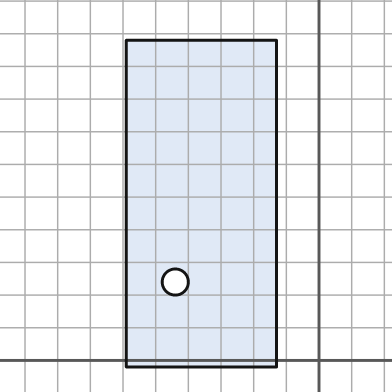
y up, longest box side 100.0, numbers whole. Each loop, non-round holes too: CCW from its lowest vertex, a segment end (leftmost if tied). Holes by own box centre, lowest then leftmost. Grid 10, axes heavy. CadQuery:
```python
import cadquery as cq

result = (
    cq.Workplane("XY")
    .moveTo(-59.0, -2.0)
    .lineTo(-13.0, -2.0)
    .lineTo(-13.0, 98.0)
    .lineTo(-59.0, 98.0)
    .close()
    .moveTo(-44.0, 24.0)
    .circle(4.0)
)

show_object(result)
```